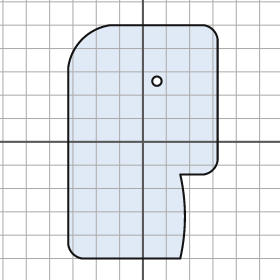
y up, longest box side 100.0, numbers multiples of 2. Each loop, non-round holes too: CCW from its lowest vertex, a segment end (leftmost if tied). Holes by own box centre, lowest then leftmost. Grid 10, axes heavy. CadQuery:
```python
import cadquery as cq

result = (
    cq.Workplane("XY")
    .moveTo(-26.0, -50.0)
    .lineTo(16.0, -50.0)
    .threePointArc((18.0, -32.0), (16.0, -14.0))
    .lineTo(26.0, -14.0)
    .threePointArc((30.0, -12.0), (32.0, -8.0))
    .lineTo(32.0, 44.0)
    .threePointArc((30.0, 48.0), (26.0, 50.0))
    .lineTo(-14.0, 50.0)
    .threePointArc((-26.0, 44.0), (-32.0, 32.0))
    .lineTo(-32.0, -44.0)
    .threePointArc((-30.0, -48.0), (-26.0, -50.0))
    .close()
    .moveTo(6.0, 26.0)
    .circle(2.0)
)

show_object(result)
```